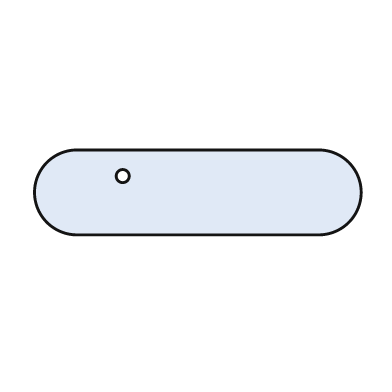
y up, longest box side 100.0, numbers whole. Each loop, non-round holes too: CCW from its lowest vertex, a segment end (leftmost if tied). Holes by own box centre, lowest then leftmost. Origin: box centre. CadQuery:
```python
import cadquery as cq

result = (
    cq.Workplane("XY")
    .moveTo(-37.0, -13.0)
    .lineTo(37.0, -13.0)
    .threePointArc((50.0, 0.0), (37.0, 13.0))
    .lineTo(-37.0, 13.0)
    .threePointArc((-50.0, 0.0), (-37.0, -13.0))
    .close()
    .moveTo(-23.0, 5.0)
    .circle(2.0)
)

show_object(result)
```